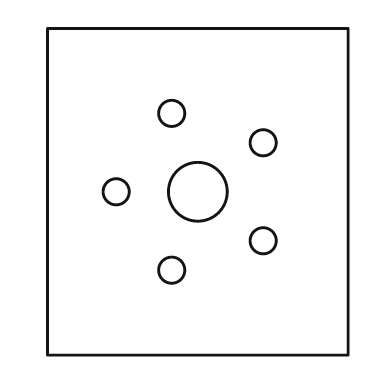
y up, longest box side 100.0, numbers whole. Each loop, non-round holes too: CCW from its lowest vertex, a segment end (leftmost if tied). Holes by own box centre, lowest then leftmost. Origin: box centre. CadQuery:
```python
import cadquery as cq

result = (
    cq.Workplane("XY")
    .moveTo(-46.0, -50.0)
    .lineTo(46.0, -50.0)
    .lineTo(46.0, 50.0)
    .lineTo(-46.0, 50.0)
    .close()
    .moveTo(-8.0, -24.0)
    .circle(4.0)
    .moveTo(20.0, -15.0)
    .circle(4.0)
    .moveTo(-25.0, 0.0)
    .circle(4.0)
    .moveTo(0.0, 0.0)
    .circle(9.0)
    .moveTo(20.0, 15.0)
    .circle(4.0)
    .moveTo(-8.0, 24.0)
    .circle(4.0)
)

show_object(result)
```